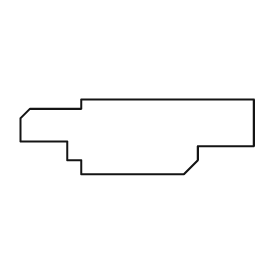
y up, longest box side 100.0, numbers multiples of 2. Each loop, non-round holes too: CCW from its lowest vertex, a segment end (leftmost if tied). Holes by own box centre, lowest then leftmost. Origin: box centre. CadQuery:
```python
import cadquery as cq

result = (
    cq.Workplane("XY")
    .moveTo(-24.0, -16.0)
    .lineTo(20.0, -16.0)
    .lineTo(26.0, -10.0)
    .lineTo(26.0, -4.0)
    .lineTo(50.0, -4.0)
    .lineTo(50.0, 16.0)
    .lineTo(-24.0, 16.0)
    .lineTo(-24.0, 12.0)
    .lineTo(-46.0, 12.0)
    .lineTo(-50.0, 8.0)
    .lineTo(-50.0, -2.0)
    .lineTo(-30.0, -2.0)
    .lineTo(-30.0, -10.0)
    .lineTo(-24.0, -10.0)
    .close()
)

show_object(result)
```